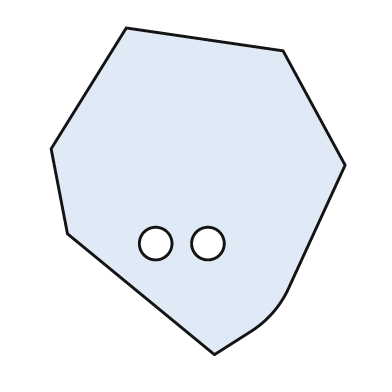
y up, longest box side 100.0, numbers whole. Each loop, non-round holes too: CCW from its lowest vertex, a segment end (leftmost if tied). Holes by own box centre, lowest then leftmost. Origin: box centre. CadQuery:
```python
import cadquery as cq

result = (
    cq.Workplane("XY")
    .moveTo(5.0, -50.0)
    .lineTo(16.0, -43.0)
    .threePointArc((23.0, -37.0), (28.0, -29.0))
    .lineTo(45.0, 8.0)
    .lineTo(26.0, 43.0)
    .lineTo(-22.0, 50.0)
    .lineTo(-45.0, 13.0)
    .lineTo(-40.0, -13.0)
    .close()
    .moveTo(-13.0, -16.0)
    .circle(5.0)
    .moveTo(3.0, -16.0)
    .circle(5.0)
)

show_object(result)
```